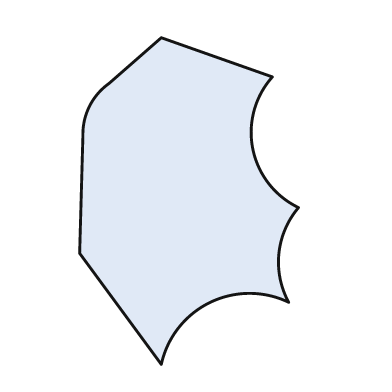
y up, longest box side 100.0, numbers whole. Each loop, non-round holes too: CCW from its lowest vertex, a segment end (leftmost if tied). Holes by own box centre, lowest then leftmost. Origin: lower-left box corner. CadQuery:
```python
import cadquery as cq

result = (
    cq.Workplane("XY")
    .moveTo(25.0, 0.0)
    .threePointArc((40.0, 19.0), (64.0, 19.0))
    .threePointArc((61.0, 34.0), (67.0, 48.0))
    .threePointArc((53.0, 66.0), (59.0, 88.0))
    .lineTo(25.0, 100.0)
    .lineTo(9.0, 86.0)
    .threePointArc((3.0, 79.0), (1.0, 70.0))
    .lineTo(0.0, 34.0)
    .close()
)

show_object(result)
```